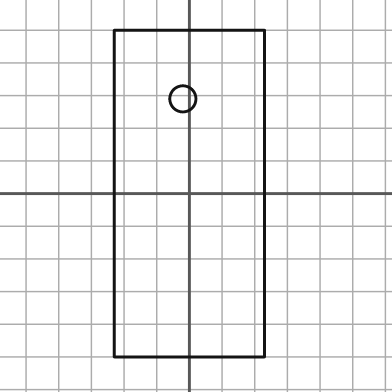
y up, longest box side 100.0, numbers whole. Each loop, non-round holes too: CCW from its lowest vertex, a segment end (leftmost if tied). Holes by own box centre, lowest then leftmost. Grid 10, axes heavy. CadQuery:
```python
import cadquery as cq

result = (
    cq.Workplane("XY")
    .moveTo(-23.0, -50.0)
    .lineTo(23.0, -50.0)
    .lineTo(23.0, 50.0)
    .lineTo(-23.0, 50.0)
    .close()
    .moveTo(-2.0, 29.0)
    .circle(4.0)
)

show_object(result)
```